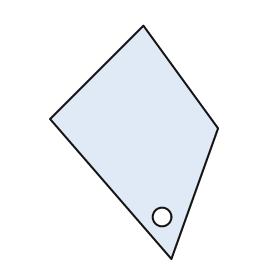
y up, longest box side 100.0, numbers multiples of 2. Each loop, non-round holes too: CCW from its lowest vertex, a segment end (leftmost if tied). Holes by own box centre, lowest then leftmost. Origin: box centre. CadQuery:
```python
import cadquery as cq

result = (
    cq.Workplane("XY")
    .moveTo(16.0, -50.0)
    .lineTo(36.0, 6.0)
    .lineTo(4.0, 50.0)
    .lineTo(-36.0, 10.0)
    .close()
    .moveTo(12.0, -32.0)
    .circle(4.0)
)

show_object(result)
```